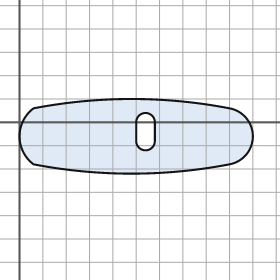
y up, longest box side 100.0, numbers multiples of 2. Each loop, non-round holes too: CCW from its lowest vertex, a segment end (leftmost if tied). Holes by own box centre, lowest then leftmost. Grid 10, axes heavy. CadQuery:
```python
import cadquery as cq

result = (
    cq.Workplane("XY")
    .moveTo(6.0, -18.0)
    .threePointArc((48.0, -22.0), (90.0, -18.0))
    .threePointArc((100.0, -6.0), (90.0, 6.0))
    .threePointArc((48.0, 10.0), (6.0, 6.0))
    .threePointArc((0.0, -6.0), (6.0, -18.0))
    .close()
    .moveTo(50.0, -8.0)
    .threePointArc((54.0, -12.0), (58.0, -8.0))
    .lineTo(58.0, 0.0)
    .threePointArc((54.0, 4.0), (50.0, 0.0))
    .close()
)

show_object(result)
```